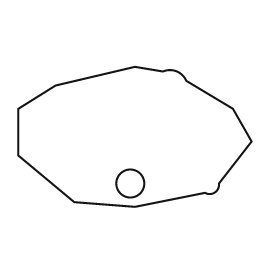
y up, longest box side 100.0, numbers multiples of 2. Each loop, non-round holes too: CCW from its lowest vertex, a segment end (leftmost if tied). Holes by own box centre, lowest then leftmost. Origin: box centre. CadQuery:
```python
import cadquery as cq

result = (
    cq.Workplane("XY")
    .moveTo(0.0, -30.0)
    .lineTo(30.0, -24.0)
    .threePointArc((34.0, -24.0), (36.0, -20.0))
    .lineTo(50.0, -2.0)
    .lineTo(42.0, 12.0)
    .lineTo(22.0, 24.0)
    .threePointArc((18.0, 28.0), (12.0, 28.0))
    .lineTo(0.0, 30.0)
    .lineTo(-34.0, 22.0)
    .lineTo(-50.0, 12.0)
    .lineTo(-50.0, -8.0)
    .lineTo(-26.0, -28.0)
    .close()
    .moveTo(-2.0, -20.0)
    .circle(6.0)
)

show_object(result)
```